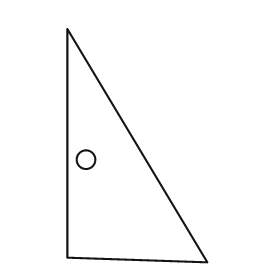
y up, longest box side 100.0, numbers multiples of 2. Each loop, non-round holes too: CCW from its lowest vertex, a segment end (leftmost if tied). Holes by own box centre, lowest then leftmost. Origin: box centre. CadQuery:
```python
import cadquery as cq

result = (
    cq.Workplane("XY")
    .moveTo(30.0, -50.0)
    .lineTo(-30.0, 50.0)
    .lineTo(-30.0, -48.0)
    .close()
    .moveTo(-22.0, -6.0)
    .circle(4.0)
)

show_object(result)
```